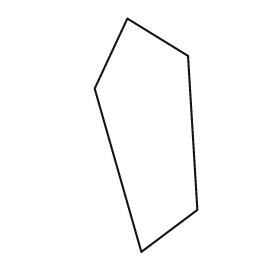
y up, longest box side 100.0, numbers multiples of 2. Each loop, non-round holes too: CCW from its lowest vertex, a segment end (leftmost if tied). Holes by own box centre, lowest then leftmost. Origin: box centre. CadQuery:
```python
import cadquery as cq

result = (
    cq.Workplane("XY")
    .moveTo(-2.0, -50.0)
    .lineTo(22.0, -32.0)
    .lineTo(18.0, 34.0)
    .lineTo(-8.0, 50.0)
    .lineTo(-22.0, 20.0)
    .close()
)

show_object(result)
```